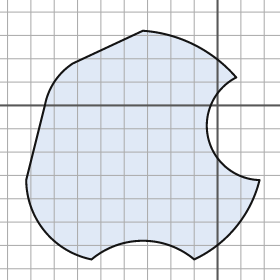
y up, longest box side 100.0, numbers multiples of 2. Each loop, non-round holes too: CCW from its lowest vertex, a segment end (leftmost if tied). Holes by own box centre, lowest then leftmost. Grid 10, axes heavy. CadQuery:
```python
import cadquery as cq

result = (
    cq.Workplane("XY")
    .moveTo(-54.0, -66.0)
    .threePointArc((-32.0, -58.0), (-10.0, -66.0))
    .threePointArc((8.0, -52.0), (18.0, -32.0))
    .threePointArc((-4.0, -14.0), (8.0, 12.0))
    .threePointArc((-10.0, 26.0), (-32.0, 32.0))
    .lineTo(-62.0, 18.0)
    .threePointArc((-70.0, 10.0), (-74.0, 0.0))
    .lineTo(-82.0, -32.0)
    .threePointArc((-74.0, -54.0), (-54.0, -66.0))
    .close()
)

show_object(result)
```